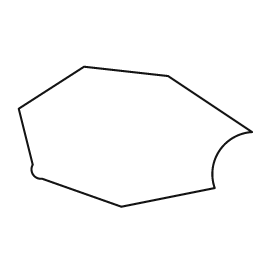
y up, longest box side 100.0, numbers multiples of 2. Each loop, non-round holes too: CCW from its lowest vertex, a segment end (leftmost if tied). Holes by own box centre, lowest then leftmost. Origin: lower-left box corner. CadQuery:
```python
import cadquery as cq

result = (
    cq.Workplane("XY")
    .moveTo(44.0, 0.0)
    .lineTo(84.0, 8.0)
    .threePointArc((86.0, 24.0), (100.0, 32.0))
    .lineTo(64.0, 56.0)
    .lineTo(28.0, 60.0)
    .lineTo(0.0, 42.0)
    .lineTo(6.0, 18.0)
    .threePointArc((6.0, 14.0), (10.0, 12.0))
    .close()
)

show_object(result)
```